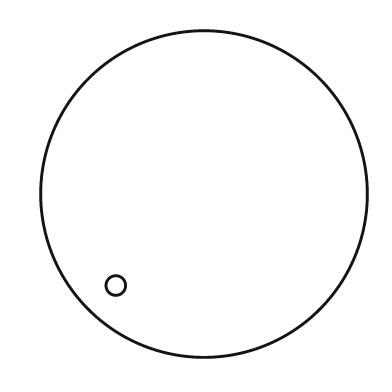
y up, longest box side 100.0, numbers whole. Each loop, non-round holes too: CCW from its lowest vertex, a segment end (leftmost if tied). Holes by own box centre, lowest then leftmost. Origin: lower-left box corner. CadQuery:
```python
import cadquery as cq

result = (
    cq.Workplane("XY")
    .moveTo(50.0, 50.0)
    .circle(50.0)
    .moveTo(23.0, 22.0)
    .circle(3.0)
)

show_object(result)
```